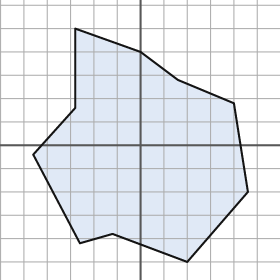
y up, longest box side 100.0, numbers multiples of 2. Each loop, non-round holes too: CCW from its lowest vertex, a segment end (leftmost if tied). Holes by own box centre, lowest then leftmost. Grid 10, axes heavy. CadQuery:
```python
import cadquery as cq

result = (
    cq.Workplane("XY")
    .moveTo(20.0, -50.0)
    .lineTo(46.0, -20.0)
    .lineTo(40.0, 18.0)
    .lineTo(16.0, 28.0)
    .lineTo(0.0, 40.0)
    .lineTo(-28.0, 50.0)
    .lineTo(-28.0, 16.0)
    .lineTo(-46.0, -4.0)
    .lineTo(-26.0, -42.0)
    .lineTo(-12.0, -38.0)
    .close()
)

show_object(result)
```